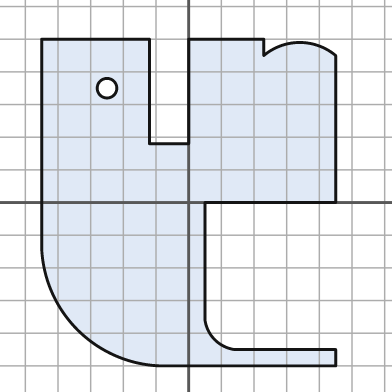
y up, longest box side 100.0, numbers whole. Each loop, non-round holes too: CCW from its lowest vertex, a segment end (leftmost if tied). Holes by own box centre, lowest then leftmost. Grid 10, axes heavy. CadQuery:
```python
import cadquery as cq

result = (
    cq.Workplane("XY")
    .moveTo(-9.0, -50.0)
    .lineTo(45.0, -50.0)
    .lineTo(45.0, -45.0)
    .lineTo(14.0, -45.0)
    .threePointArc((8.0, -42.0), (5.0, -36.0))
    .lineTo(5.0, 0.0)
    .lineTo(45.0, 0.0)
    .lineTo(45.0, 45.0)
    .threePointArc((34.0, 49.0), (23.0, 45.0))
    .lineTo(23.0, 50.0)
    .lineTo(0.0, 50.0)
    .lineTo(0.0, 18.0)
    .lineTo(-12.0, 18.0)
    .lineTo(-12.0, 50.0)
    .lineTo(-45.0, 50.0)
    .lineTo(-45.0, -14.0)
    .threePointArc((-34.0, -39.0), (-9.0, -50.0))
    .close()
    .moveTo(-25.0, 35.0)
    .circle(3.0)
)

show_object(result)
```